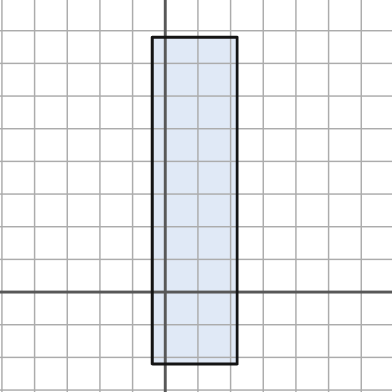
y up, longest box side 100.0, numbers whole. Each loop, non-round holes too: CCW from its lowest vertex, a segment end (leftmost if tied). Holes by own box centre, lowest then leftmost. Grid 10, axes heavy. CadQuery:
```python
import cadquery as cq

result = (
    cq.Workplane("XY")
    .moveTo(-4.0, -22.0)
    .lineTo(22.0, -22.0)
    .lineTo(22.0, 78.0)
    .lineTo(-4.0, 78.0)
    .close()
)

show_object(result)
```